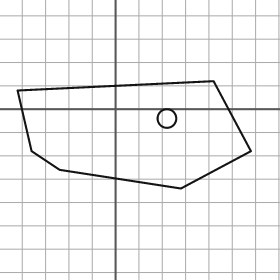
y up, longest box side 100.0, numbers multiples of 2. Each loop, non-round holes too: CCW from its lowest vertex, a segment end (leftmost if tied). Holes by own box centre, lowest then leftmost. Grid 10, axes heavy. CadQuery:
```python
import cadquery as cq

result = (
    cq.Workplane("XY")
    .moveTo(28.0, -34.0)
    .lineTo(58.0, -18.0)
    .lineTo(42.0, 12.0)
    .lineTo(-42.0, 8.0)
    .lineTo(-36.0, -18.0)
    .lineTo(-24.0, -26.0)
    .close()
    .moveTo(22.0, -4.0)
    .circle(4.0)
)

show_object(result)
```